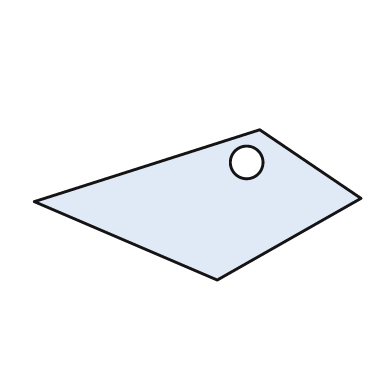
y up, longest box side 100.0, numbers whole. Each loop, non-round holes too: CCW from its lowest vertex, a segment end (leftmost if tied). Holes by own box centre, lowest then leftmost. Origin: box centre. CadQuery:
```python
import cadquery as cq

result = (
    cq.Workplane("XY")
    .moveTo(6.0, -23.0)
    .lineTo(50.0, 2.0)
    .lineTo(19.0, 23.0)
    .lineTo(-50.0, 1.0)
    .close()
    .moveTo(15.0, 13.0)
    .circle(5.0)
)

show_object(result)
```